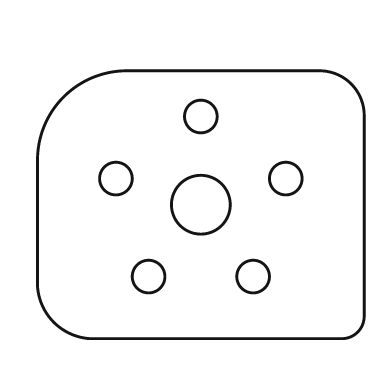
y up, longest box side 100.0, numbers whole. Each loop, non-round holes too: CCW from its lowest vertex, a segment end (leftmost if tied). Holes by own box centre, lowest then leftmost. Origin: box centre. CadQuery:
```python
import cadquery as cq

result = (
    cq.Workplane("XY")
    .moveTo(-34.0, -41.0)
    .lineTo(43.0, -41.0)
    .threePointArc((48.0, -39.0), (50.0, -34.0))
    .lineTo(50.0, 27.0)
    .threePointArc((46.0, 37.0), (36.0, 41.0))
    .lineTo(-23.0, 41.0)
    .threePointArc((-42.0, 33.0), (-50.0, 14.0))
    .lineTo(-50.0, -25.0)
    .threePointArc((-45.0, -36.0), (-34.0, -41.0))
    .close()
    .moveTo(-16.0, -22.0)
    .circle(5.0)
    .moveTo(16.0, -22.0)
    .circle(5.0)
    .moveTo(0.0, 0.0)
    .circle(9.0)
    .moveTo(-26.0, 8.0)
    .circle(5.0)
    .moveTo(26.0, 8.0)
    .circle(5.0)
    .moveTo(0.0, 27.0)
    .circle(5.0)
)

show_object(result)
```